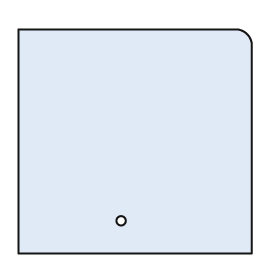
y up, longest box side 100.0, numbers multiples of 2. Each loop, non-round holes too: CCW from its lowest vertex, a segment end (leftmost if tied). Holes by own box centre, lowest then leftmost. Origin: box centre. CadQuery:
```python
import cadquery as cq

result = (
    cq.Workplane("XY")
    .moveTo(-50.0, -48.0)
    .lineTo(50.0, -48.0)
    .lineTo(50.0, 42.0)
    .threePointArc((48.0, 46.0), (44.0, 48.0))
    .lineTo(-50.0, 48.0)
    .close()
    .moveTo(-6.0, -34.0)
    .circle(2.0)
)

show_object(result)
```